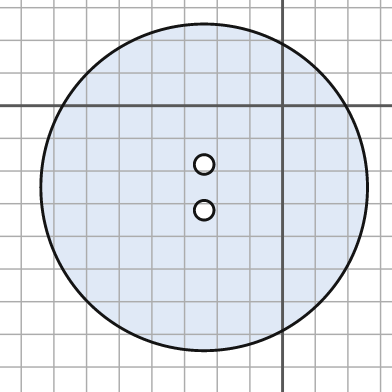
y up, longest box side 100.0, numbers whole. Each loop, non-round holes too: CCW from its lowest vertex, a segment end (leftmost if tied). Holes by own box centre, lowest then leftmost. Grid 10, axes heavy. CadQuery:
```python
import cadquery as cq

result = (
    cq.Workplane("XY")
    .moveTo(-24.0, -25.0)
    .circle(50.0)
    .moveTo(-24.0, -32.0)
    .circle(3.0)
    .moveTo(-24.0, -18.0)
    .circle(3.0)
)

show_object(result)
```